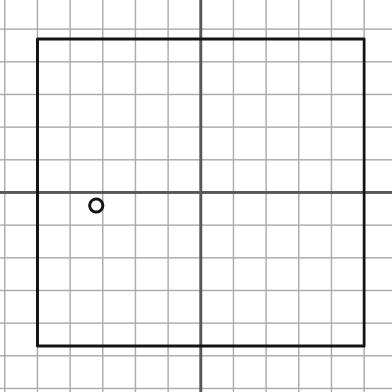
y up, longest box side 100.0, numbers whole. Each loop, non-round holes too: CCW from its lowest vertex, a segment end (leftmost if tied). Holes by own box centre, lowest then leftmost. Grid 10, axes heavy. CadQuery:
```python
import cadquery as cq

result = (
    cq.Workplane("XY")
    .moveTo(-50.0, -47.0)
    .lineTo(50.0, -47.0)
    .lineTo(50.0, 47.0)
    .lineTo(-50.0, 47.0)
    .close()
    .moveTo(-32.0, -4.0)
    .circle(2.0)
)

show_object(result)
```